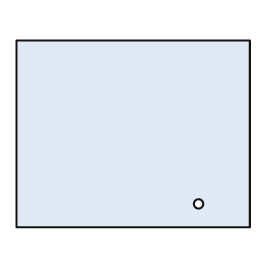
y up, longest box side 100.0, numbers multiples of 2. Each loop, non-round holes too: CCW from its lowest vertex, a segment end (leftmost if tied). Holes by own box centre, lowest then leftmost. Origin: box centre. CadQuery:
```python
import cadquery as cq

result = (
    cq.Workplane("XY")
    .moveTo(-50.0, -40.0)
    .lineTo(50.0, -40.0)
    .lineTo(50.0, 40.0)
    .lineTo(-50.0, 40.0)
    .close()
    .moveTo(28.0, -30.0)
    .circle(2.0)
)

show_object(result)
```